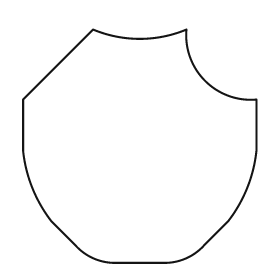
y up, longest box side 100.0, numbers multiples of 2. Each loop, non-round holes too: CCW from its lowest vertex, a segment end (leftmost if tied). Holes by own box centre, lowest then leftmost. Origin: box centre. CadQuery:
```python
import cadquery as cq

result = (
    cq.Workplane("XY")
    .moveTo(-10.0, -50.0)
    .lineTo(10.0, -50.0)
    .threePointArc((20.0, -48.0), (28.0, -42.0))
    .lineTo(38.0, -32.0)
    .threePointArc((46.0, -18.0), (50.0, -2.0))
    .lineTo(50.0, 20.0)
    .threePointArc((28.0, 28.0), (20.0, 50.0))
    .threePointArc((0.0, 46.0), (-20.0, 50.0))
    .lineTo(-50.0, 20.0)
    .lineTo(-50.0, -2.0)
    .threePointArc((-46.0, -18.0), (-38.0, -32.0))
    .lineTo(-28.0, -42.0)
    .threePointArc((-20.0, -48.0), (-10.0, -50.0))
    .close()
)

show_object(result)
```